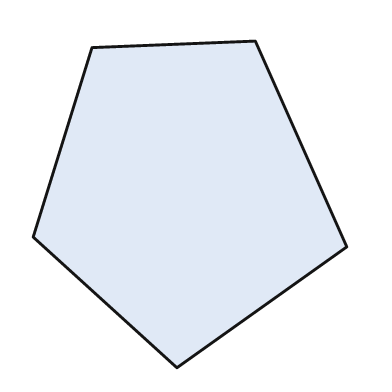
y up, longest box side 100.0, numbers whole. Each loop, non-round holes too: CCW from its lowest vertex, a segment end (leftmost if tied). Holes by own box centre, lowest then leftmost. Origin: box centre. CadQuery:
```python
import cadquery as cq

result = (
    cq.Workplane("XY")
    .moveTo(-4.0, -50.0)
    .lineTo(48.0, -13.0)
    .lineTo(20.0, 50.0)
    .lineTo(-30.0, 48.0)
    .lineTo(-48.0, -10.0)
    .close()
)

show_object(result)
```